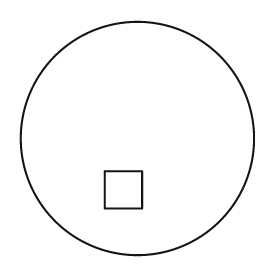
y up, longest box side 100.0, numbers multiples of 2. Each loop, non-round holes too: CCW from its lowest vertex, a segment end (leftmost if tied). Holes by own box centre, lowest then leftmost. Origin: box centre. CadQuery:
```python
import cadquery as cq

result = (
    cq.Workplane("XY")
    .moveTo(0.0, 0.0)
    .circle(50.0)
    .moveTo(-14.0, -30.0)
    .lineTo(2.0, -30.0)
    .lineTo(2.0, -14.0)
    .lineTo(-14.0, -14.0)
    .close()
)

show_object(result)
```